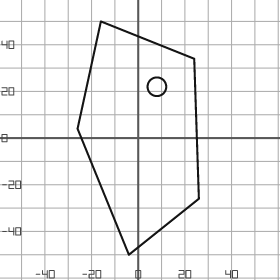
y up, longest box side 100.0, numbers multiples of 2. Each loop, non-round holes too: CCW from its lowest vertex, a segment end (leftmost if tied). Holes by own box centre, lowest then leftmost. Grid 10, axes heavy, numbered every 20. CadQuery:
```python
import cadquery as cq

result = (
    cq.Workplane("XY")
    .moveTo(-4.0, -50.0)
    .lineTo(26.0, -26.0)
    .lineTo(24.0, 34.0)
    .lineTo(-16.0, 50.0)
    .lineTo(-26.0, 4.0)
    .close()
    .moveTo(8.0, 22.0)
    .circle(4.0)
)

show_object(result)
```